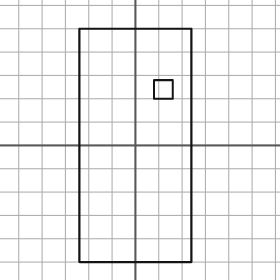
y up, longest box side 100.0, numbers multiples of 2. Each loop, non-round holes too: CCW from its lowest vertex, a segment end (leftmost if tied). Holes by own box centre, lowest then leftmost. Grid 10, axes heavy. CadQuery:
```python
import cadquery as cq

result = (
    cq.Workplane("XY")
    .moveTo(-24.0, -50.0)
    .lineTo(24.0, -50.0)
    .lineTo(24.0, 50.0)
    .lineTo(-24.0, 50.0)
    .close()
    .moveTo(8.0, 20.0)
    .lineTo(16.0, 20.0)
    .lineTo(16.0, 28.0)
    .lineTo(8.0, 28.0)
    .close()
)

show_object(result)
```